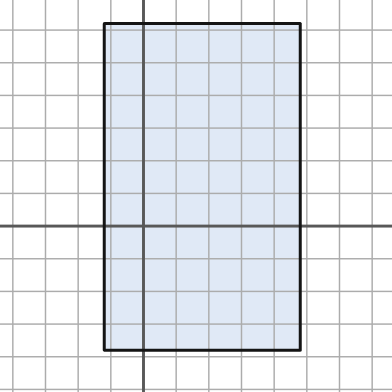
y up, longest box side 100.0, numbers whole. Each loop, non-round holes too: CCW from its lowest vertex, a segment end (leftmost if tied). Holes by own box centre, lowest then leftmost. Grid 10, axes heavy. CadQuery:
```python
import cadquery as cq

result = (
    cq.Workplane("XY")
    .moveTo(-12.0, -38.0)
    .lineTo(48.0, -38.0)
    .lineTo(48.0, 62.0)
    .lineTo(-12.0, 62.0)
    .close()
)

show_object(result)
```